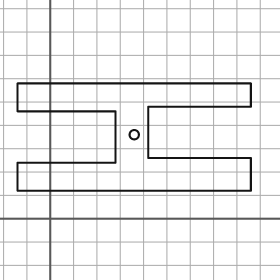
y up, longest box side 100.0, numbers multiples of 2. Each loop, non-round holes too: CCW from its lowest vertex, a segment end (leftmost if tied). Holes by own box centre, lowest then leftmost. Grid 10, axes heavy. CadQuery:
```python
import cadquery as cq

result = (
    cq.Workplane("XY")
    .moveTo(-14.0, 12.0)
    .lineTo(86.0, 12.0)
    .lineTo(86.0, 26.0)
    .lineTo(42.0, 26.0)
    .lineTo(42.0, 48.0)
    .lineTo(86.0, 48.0)
    .lineTo(86.0, 58.0)
    .lineTo(-14.0, 58.0)
    .lineTo(-14.0, 46.0)
    .lineTo(28.0, 46.0)
    .lineTo(28.0, 24.0)
    .lineTo(-14.0, 24.0)
    .close()
    .moveTo(36.0, 36.0)
    .circle(2.0)
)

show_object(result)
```